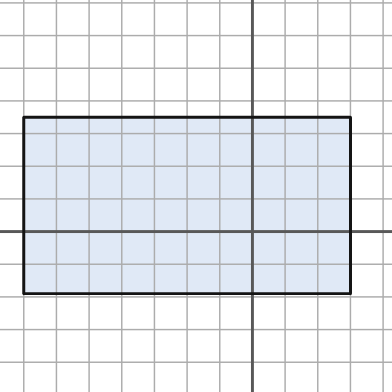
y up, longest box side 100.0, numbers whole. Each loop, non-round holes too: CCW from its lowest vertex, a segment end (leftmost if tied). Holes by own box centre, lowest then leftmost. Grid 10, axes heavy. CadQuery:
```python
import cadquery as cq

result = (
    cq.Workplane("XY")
    .moveTo(-70.0, -19.0)
    .lineTo(30.0, -19.0)
    .lineTo(30.0, 35.0)
    .lineTo(-70.0, 35.0)
    .close()
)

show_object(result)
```